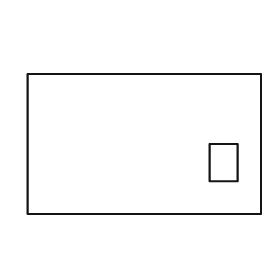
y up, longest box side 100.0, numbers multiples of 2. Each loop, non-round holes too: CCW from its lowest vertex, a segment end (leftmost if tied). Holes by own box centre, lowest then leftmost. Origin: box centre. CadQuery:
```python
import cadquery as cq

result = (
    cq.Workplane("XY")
    .moveTo(-50.0, -30.0)
    .lineTo(50.0, -30.0)
    .lineTo(50.0, 30.0)
    .lineTo(-50.0, 30.0)
    .close()
    .moveTo(28.0, -16.0)
    .lineTo(40.0, -16.0)
    .lineTo(40.0, 0.0)
    .lineTo(28.0, 0.0)
    .close()
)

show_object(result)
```